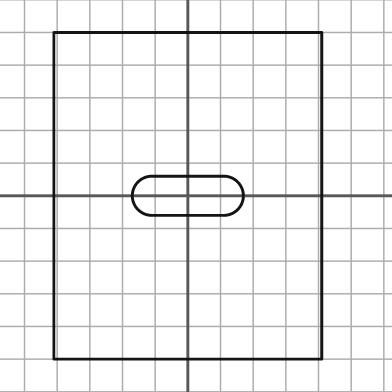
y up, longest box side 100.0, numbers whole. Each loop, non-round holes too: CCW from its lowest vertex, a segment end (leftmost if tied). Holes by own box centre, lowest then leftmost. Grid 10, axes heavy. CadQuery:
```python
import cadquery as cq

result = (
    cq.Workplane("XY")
    .moveTo(-41.0, -50.0)
    .lineTo(41.0, -50.0)
    .lineTo(41.0, 50.0)
    .lineTo(-41.0, 50.0)
    .close()
    .moveTo(-11.0, -6.0)
    .lineTo(11.0, -6.0)
    .threePointArc((17.0, 0.0), (11.0, 6.0))
    .lineTo(-11.0, 6.0)
    .threePointArc((-17.0, 0.0), (-11.0, -6.0))
    .close()
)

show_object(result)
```